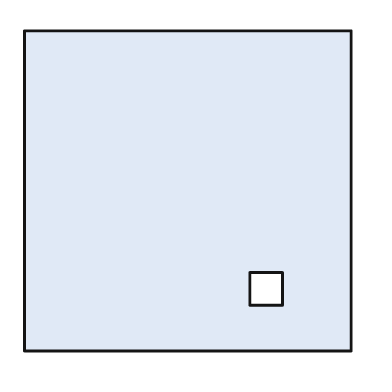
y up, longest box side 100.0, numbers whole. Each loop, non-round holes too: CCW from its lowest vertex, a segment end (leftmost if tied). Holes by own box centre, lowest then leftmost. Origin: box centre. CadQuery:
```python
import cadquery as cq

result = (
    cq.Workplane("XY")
    .moveTo(-50.0, -49.0)
    .lineTo(50.0, -49.0)
    .lineTo(50.0, 49.0)
    .lineTo(-50.0, 49.0)
    .close()
    .moveTo(19.0, -35.0)
    .lineTo(29.0, -35.0)
    .lineTo(29.0, -25.0)
    .lineTo(19.0, -25.0)
    .close()
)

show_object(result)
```